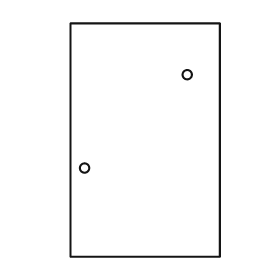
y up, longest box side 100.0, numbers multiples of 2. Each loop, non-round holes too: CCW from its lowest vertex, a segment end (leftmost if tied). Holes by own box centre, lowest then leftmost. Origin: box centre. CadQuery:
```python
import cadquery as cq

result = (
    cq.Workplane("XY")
    .moveTo(-32.0, -50.0)
    .lineTo(32.0, -50.0)
    .lineTo(32.0, 50.0)
    .lineTo(-32.0, 50.0)
    .close()
    .moveTo(-26.0, -12.0)
    .circle(2.0)
    .moveTo(18.0, 28.0)
    .circle(2.0)
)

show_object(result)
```